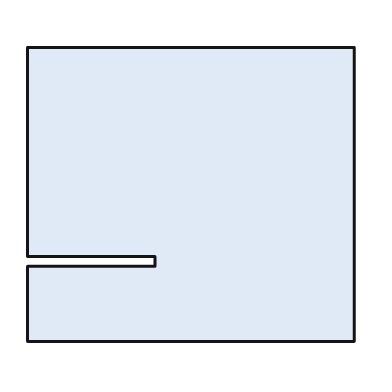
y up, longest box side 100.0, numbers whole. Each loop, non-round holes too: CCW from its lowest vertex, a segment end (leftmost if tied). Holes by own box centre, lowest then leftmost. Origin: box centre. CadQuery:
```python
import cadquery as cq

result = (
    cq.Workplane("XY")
    .moveTo(-50.0, -45.0)
    .lineTo(50.0, -45.0)
    .lineTo(50.0, 45.0)
    .lineTo(-50.0, 45.0)
    .lineTo(-50.0, -19.0)
    .lineTo(-11.0, -19.0)
    .lineTo(-11.0, -22.0)
    .lineTo(-50.0, -22.0)
    .close()
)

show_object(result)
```